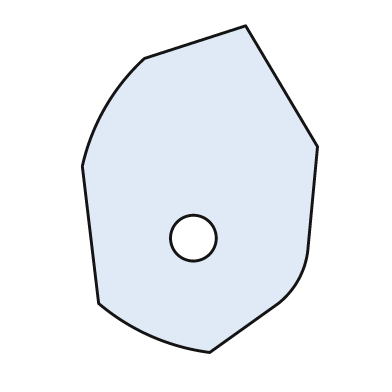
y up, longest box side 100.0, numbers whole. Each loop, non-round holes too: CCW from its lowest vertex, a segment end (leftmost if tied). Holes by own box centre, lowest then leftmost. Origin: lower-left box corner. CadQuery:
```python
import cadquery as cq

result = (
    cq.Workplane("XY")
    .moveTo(39.0, 0.0)
    .lineTo(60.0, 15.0)
    .threePointArc((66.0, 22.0), (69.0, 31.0))
    .lineTo(72.0, 63.0)
    .lineTo(50.0, 100.0)
    .lineTo(19.0, 90.0)
    .threePointArc((7.0, 75.0), (0.0, 57.0))
    .lineTo(5.0, 15.0)
    .threePointArc((21.0, 5.0), (39.0, 0.0))
    .close()
    .moveTo(34.0, 35.0)
    .circle(7.0)
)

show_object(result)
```